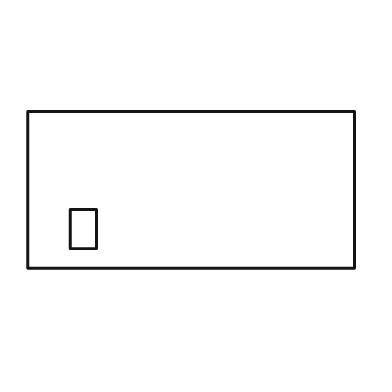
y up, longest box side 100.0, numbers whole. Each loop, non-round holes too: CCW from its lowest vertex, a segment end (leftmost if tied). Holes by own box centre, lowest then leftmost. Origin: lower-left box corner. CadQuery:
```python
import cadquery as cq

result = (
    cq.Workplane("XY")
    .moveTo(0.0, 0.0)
    .lineTo(100.0, 0.0)
    .lineTo(100.0, 48.0)
    .lineTo(0.0, 48.0)
    .close()
    .moveTo(13.0, 6.0)
    .lineTo(21.0, 6.0)
    .lineTo(21.0, 18.0)
    .lineTo(13.0, 18.0)
    .close()
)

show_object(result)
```